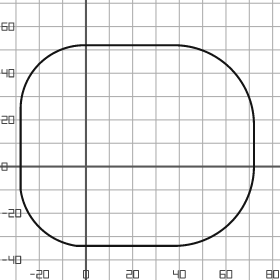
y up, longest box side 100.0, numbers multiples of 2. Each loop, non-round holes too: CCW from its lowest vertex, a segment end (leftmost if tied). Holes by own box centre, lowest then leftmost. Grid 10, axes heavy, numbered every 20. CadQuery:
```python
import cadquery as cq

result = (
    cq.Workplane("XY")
    .moveTo(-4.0, -34.0)
    .lineTo(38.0, -34.0)
    .threePointArc((62.0, -24.0), (72.0, 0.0))
    .lineTo(72.0, 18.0)
    .threePointArc((62.0, 42.0), (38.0, 52.0))
    .lineTo(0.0, 52.0)
    .threePointArc((-20.0, 44.0), (-28.0, 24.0))
    .lineTo(-28.0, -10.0)
    .threePointArc((-20.0, -26.0), (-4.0, -34.0))
    .close()
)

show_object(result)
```